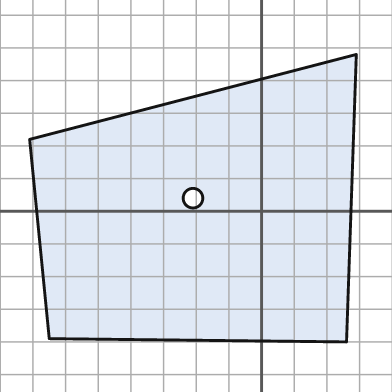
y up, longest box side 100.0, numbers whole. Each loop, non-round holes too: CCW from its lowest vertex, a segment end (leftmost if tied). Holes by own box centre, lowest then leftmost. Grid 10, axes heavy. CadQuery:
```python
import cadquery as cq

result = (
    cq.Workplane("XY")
    .moveTo(26.0, -40.0)
    .lineTo(29.0, 48.0)
    .lineTo(-71.0, 22.0)
    .lineTo(-65.0, -39.0)
    .close()
    .moveTo(-21.0, 4.0)
    .circle(3.0)
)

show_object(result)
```